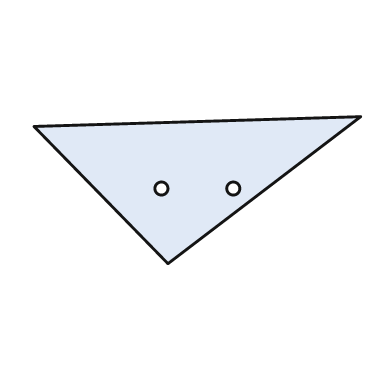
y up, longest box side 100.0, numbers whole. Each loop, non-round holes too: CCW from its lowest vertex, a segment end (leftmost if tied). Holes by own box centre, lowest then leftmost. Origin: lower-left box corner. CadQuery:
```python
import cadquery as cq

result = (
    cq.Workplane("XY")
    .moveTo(41.0, 0.0)
    .lineTo(100.0, 45.0)
    .lineTo(0.0, 42.0)
    .close()
    .moveTo(39.0, 23.0)
    .circle(2.0)
    .moveTo(61.0, 23.0)
    .circle(2.0)
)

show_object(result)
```